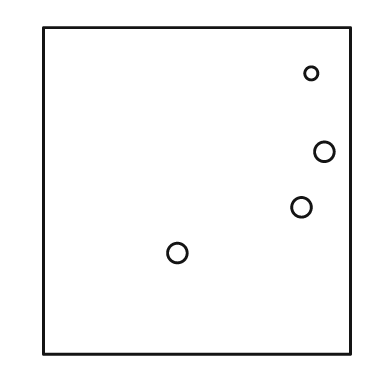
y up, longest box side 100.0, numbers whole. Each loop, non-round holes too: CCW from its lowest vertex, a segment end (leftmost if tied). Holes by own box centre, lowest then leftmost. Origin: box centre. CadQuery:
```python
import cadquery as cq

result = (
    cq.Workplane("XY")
    .moveTo(-47.0, -50.0)
    .lineTo(47.0, -50.0)
    .lineTo(47.0, 50.0)
    .lineTo(-47.0, 50.0)
    .close()
    .moveTo(-6.0, -19.0)
    .circle(3.0)
    .moveTo(32.0, -5.0)
    .circle(3.0)
    .moveTo(39.0, 12.0)
    .circle(3.0)
    .moveTo(35.0, 36.0)
    .circle(2.0)
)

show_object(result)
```